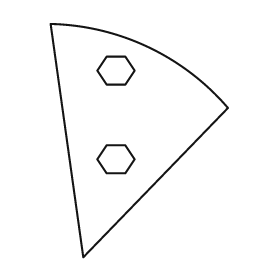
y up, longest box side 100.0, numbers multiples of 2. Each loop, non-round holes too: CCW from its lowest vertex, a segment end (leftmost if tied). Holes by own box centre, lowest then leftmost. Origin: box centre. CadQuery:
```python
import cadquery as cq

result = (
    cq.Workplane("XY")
    .moveTo(-24.0, -50.0)
    .lineTo(38.0, 14.0)
    .threePointArc((4.0, 40.0), (-38.0, 50.0))
    .close()
    .moveTo(-14.0, -14.0)
    .lineTo(-6.0, -14.0)
    .lineTo(-2.0, -8.0)
    .lineTo(-6.0, -2.0)
    .lineTo(-14.0, -2.0)
    .lineTo(-18.0, -8.0)
    .close()
    .moveTo(-14.0, 24.0)
    .lineTo(-6.0, 24.0)
    .lineTo(-2.0, 30.0)
    .lineTo(-6.0, 36.0)
    .lineTo(-14.0, 36.0)
    .lineTo(-18.0, 30.0)
    .close()
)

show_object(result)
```